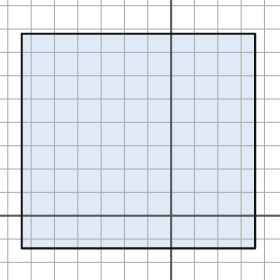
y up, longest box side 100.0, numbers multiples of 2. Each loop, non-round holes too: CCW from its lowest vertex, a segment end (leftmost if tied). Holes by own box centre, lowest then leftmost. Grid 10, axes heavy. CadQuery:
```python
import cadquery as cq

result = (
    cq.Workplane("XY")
    .moveTo(-64.0, -14.0)
    .lineTo(36.0, -14.0)
    .lineTo(36.0, 78.0)
    .lineTo(-64.0, 78.0)
    .close()
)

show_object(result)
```